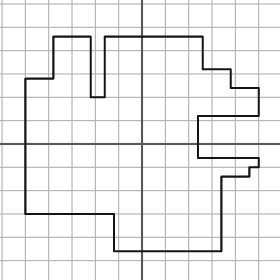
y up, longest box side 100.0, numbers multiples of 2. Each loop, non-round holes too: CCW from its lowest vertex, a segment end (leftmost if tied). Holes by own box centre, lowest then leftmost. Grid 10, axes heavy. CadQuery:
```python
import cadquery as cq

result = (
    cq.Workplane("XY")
    .moveTo(-12.0, -46.0)
    .lineTo(34.0, -46.0)
    .lineTo(34.0, -14.0)
    .lineTo(46.0, -14.0)
    .lineTo(46.0, -10.0)
    .lineTo(50.0, -10.0)
    .lineTo(50.0, -6.0)
    .lineTo(24.0, -6.0)
    .lineTo(24.0, 12.0)
    .lineTo(50.0, 12.0)
    .lineTo(50.0, 24.0)
    .lineTo(38.0, 24.0)
    .lineTo(38.0, 32.0)
    .lineTo(26.0, 32.0)
    .lineTo(26.0, 46.0)
    .lineTo(-16.0, 46.0)
    .lineTo(-16.0, 20.0)
    .lineTo(-22.0, 20.0)
    .lineTo(-22.0, 46.0)
    .lineTo(-38.0, 46.0)
    .lineTo(-38.0, 28.0)
    .lineTo(-50.0, 28.0)
    .lineTo(-50.0, -30.0)
    .lineTo(-12.0, -30.0)
    .close()
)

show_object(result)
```